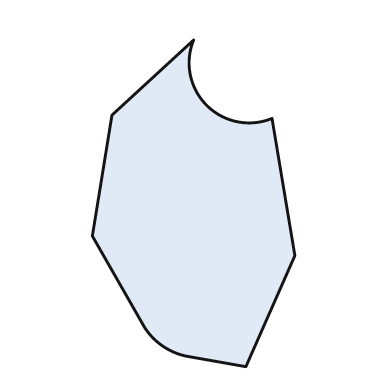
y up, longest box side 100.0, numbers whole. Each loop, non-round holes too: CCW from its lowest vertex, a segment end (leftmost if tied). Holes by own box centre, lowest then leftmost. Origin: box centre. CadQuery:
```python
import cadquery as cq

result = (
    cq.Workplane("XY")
    .moveTo(16.0, -50.0)
    .lineTo(31.0, -16.0)
    .lineTo(24.0, 26.0)
    .threePointArc((4.0, 30.0), (0.0, 50.0))
    .lineTo(-25.0, 27.0)
    .lineTo(-31.0, -10.0)
    .lineTo(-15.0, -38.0)
    .threePointArc((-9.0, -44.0), (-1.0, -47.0))
    .close()
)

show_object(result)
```